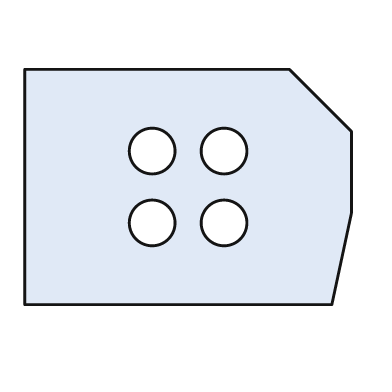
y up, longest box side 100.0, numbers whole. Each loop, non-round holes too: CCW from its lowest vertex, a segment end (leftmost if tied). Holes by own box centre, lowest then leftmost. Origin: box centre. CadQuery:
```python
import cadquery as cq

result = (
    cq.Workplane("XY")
    .moveTo(-50.0, -36.0)
    .lineTo(44.0, -36.0)
    .lineTo(50.0, -8.0)
    .lineTo(50.0, 17.0)
    .lineTo(31.0, 36.0)
    .lineTo(-50.0, 36.0)
    .close()
    .moveTo(-11.0, -11.0)
    .circle(7.0)
    .moveTo(11.0, -11.0)
    .circle(7.0)
    .moveTo(-11.0, 11.0)
    .circle(7.0)
    .moveTo(11.0, 11.0)
    .circle(7.0)
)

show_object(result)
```